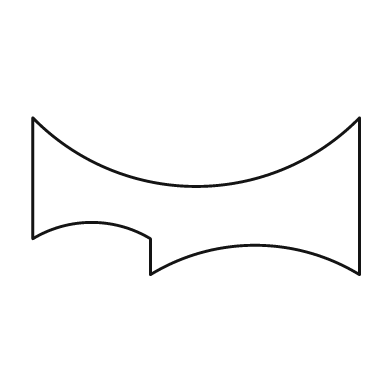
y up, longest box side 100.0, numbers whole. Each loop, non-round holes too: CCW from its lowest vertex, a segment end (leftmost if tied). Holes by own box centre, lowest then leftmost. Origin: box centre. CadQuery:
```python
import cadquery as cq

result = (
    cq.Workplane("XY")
    .moveTo(-14.0, -24.0)
    .threePointArc((18.0, -15.0), (50.0, -24.0))
    .lineTo(50.0, 24.0)
    .threePointArc((0.0, 3.0), (-50.0, 24.0))
    .lineTo(-50.0, -13.0)
    .threePointArc((-32.0, -8.0), (-14.0, -13.0))
    .close()
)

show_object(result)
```